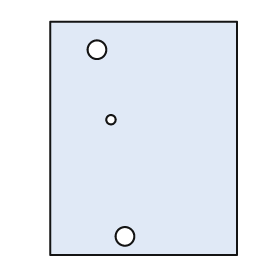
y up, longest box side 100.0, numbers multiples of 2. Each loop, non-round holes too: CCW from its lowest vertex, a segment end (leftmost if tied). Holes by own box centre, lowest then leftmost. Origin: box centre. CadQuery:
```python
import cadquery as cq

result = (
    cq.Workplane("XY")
    .moveTo(-40.0, -50.0)
    .lineTo(40.0, -50.0)
    .lineTo(40.0, 50.0)
    .lineTo(-40.0, 50.0)
    .close()
    .moveTo(-8.0, -42.0)
    .circle(4.0)
    .moveTo(-14.0, 8.0)
    .circle(2.0)
    .moveTo(-20.0, 38.0)
    .circle(4.0)
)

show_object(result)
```